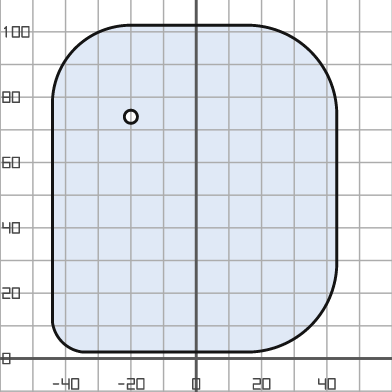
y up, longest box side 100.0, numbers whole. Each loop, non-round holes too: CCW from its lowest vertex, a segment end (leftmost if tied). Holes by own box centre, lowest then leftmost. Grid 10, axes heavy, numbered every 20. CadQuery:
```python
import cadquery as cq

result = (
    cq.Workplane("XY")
    .moveTo(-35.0, 2.0)
    .lineTo(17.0, 2.0)
    .threePointArc((35.0, 10.0), (43.0, 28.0))
    .lineTo(43.0, 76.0)
    .threePointArc((35.0, 94.0), (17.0, 102.0))
    .lineTo(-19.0, 102.0)
    .threePointArc((-37.0, 95.0), (-44.0, 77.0))
    .lineTo(-44.0, 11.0)
    .threePointArc((-41.0, 5.0), (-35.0, 2.0))
    .close()
    .moveTo(-20.0, 74.0)
    .circle(2.0)
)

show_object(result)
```